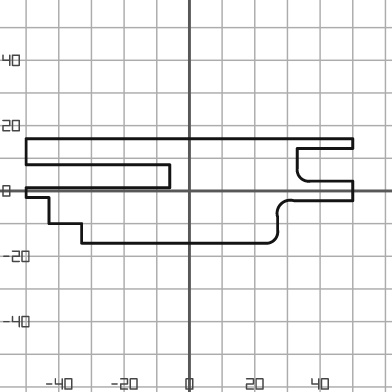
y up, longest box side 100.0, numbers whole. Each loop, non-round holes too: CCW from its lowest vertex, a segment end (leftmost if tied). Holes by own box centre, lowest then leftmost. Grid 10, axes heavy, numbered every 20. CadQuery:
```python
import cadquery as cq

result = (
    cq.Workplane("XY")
    .moveTo(-33.0, -16.0)
    .lineTo(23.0, -16.0)
    .threePointArc((26.0, -15.0), (27.0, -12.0))
    .lineTo(27.0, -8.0)
    .threePointArc((28.0, -4.0), (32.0, -3.0))
    .lineTo(50.0, -3.0)
    .lineTo(50.0, 3.0)
    .lineTo(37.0, 3.0)
    .threePointArc((34.0, 4.0), (33.0, 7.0))
    .lineTo(33.0, 13.0)
    .lineTo(50.0, 13.0)
    .lineTo(50.0, 16.0)
    .lineTo(-50.0, 16.0)
    .lineTo(-50.0, 8.0)
    .lineTo(-6.0, 8.0)
    .lineTo(-6.0, 1.0)
    .lineTo(-50.0, 1.0)
    .lineTo(-50.0, -2.0)
    .lineTo(-43.0, -2.0)
    .lineTo(-43.0, -10.0)
    .lineTo(-33.0, -10.0)
    .close()
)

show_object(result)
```